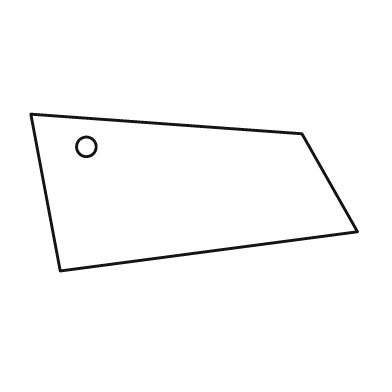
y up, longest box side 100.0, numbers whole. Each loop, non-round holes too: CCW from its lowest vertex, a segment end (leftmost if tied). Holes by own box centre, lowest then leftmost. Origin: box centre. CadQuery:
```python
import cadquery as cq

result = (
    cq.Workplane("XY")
    .moveTo(-41.0, -24.0)
    .lineTo(50.0, -12.0)
    .lineTo(33.0, 18.0)
    .lineTo(-50.0, 24.0)
    .close()
    .moveTo(-33.0, 14.0)
    .circle(3.0)
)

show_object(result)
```